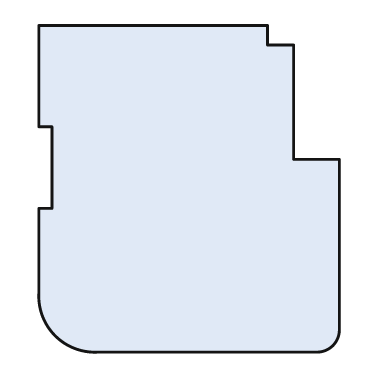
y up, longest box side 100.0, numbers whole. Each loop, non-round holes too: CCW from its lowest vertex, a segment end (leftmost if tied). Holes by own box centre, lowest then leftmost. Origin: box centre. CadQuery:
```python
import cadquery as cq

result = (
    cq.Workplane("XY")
    .moveTo(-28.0, -50.0)
    .lineTo(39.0, -50.0)
    .threePointArc((44.0, -48.0), (46.0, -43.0))
    .lineTo(46.0, 9.0)
    .lineTo(32.0, 9.0)
    .lineTo(32.0, 44.0)
    .lineTo(24.0, 44.0)
    .lineTo(24.0, 50.0)
    .lineTo(-46.0, 50.0)
    .lineTo(-46.0, 19.0)
    .lineTo(-42.0, 19.0)
    .lineTo(-42.0, -6.0)
    .lineTo(-46.0, -6.0)
    .lineTo(-46.0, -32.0)
    .threePointArc((-41.0, -45.0), (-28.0, -50.0))
    .close()
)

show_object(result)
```